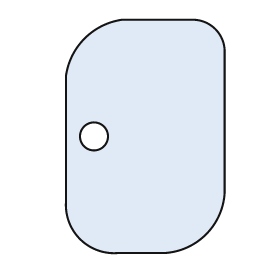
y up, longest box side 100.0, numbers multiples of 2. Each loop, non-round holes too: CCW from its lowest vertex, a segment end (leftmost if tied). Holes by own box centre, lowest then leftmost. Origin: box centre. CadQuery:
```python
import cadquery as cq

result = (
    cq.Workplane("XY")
    .moveTo(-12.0, -50.0)
    .lineTo(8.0, -50.0)
    .threePointArc((26.0, -42.0), (34.0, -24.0))
    .lineTo(34.0, 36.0)
    .threePointArc((30.0, 46.0), (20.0, 50.0))
    .lineTo(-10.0, 50.0)
    .threePointArc((-26.0, 42.0), (-34.0, 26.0))
    .lineTo(-34.0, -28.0)
    .threePointArc((-28.0, -44.0), (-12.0, -50.0))
    .close()
    .moveTo(-22.0, 0.0)
    .circle(6.0)
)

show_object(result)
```